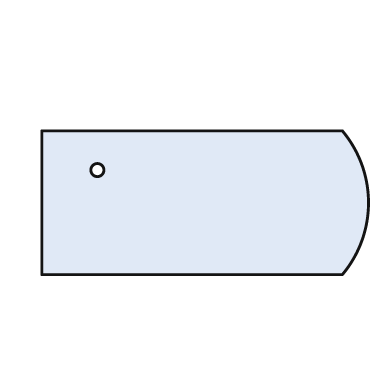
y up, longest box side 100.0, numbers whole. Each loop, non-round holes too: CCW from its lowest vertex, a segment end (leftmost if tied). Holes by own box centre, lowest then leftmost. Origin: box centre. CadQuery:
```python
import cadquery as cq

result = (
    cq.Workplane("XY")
    .moveTo(-50.0, -22.0)
    .lineTo(42.0, -22.0)
    .threePointArc((50.0, 0.0), (42.0, 22.0))
    .lineTo(-50.0, 22.0)
    .close()
    .moveTo(-33.0, 10.0)
    .circle(2.0)
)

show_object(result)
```